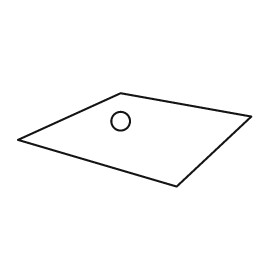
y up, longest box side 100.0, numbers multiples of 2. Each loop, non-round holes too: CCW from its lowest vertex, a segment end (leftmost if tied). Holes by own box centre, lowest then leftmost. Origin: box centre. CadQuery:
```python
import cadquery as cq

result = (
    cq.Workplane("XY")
    .moveTo(18.0, -20.0)
    .lineTo(50.0, 10.0)
    .lineTo(-6.0, 20.0)
    .lineTo(-50.0, 0.0)
    .close()
    .moveTo(-6.0, 8.0)
    .circle(4.0)
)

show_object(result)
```